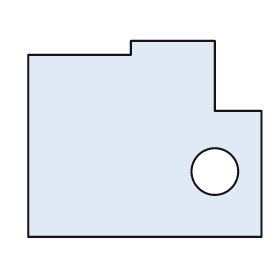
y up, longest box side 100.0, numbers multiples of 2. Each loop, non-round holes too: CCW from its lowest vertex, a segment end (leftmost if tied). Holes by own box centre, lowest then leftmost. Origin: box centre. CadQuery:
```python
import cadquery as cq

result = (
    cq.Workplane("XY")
    .moveTo(-50.0, -42.0)
    .lineTo(50.0, -42.0)
    .lineTo(50.0, 12.0)
    .lineTo(30.0, 12.0)
    .lineTo(30.0, 42.0)
    .lineTo(-6.0, 42.0)
    .lineTo(-6.0, 36.0)
    .lineTo(-50.0, 36.0)
    .close()
    .moveTo(30.0, -14.0)
    .circle(10.0)
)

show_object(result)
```